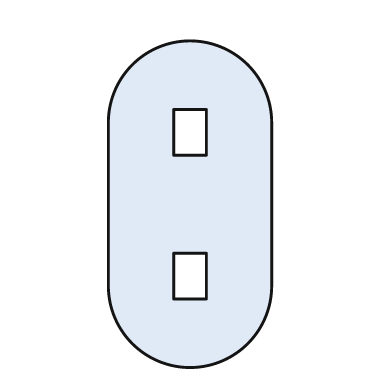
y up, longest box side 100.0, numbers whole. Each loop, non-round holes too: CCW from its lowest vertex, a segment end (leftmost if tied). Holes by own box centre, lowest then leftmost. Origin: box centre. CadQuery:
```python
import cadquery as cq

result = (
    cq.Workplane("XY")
    .moveTo(-25.0, -25.0)
    .threePointArc((0.0, -50.0), (25.0, -25.0))
    .lineTo(25.0, 25.0)
    .threePointArc((0.0, 50.0), (-25.0, 25.0))
    .close()
    .moveTo(-5.0, -29.0)
    .lineTo(5.0, -29.0)
    .lineTo(5.0, -15.0)
    .lineTo(-5.0, -15.0)
    .close()
    .moveTo(-5.0, 15.0)
    .lineTo(5.0, 15.0)
    .lineTo(5.0, 29.0)
    .lineTo(-5.0, 29.0)
    .close()
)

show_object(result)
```